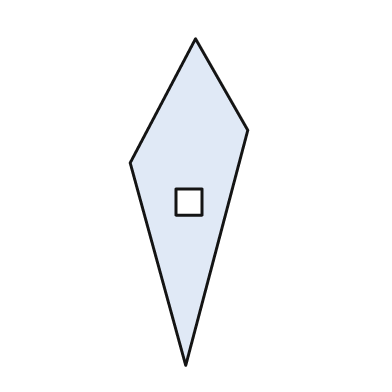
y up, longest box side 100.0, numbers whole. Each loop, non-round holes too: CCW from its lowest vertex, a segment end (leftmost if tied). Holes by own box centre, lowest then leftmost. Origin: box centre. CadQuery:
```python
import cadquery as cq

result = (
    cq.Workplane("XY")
    .moveTo(-1.0, -50.0)
    .lineTo(18.0, 22.0)
    .lineTo(2.0, 50.0)
    .lineTo(-18.0, 12.0)
    .close()
    .moveTo(-4.0, -4.0)
    .lineTo(4.0, -4.0)
    .lineTo(4.0, 4.0)
    .lineTo(-4.0, 4.0)
    .close()
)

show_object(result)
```